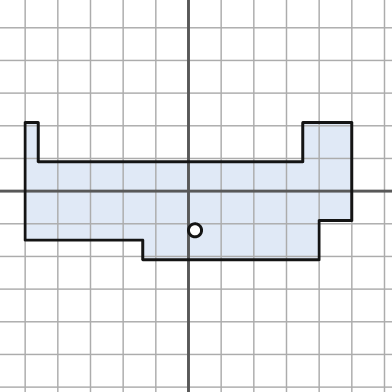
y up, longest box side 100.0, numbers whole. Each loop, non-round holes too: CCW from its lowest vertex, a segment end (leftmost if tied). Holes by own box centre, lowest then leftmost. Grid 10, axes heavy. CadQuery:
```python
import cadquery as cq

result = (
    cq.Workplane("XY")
    .moveTo(-14.0, -21.0)
    .lineTo(40.0, -21.0)
    .lineTo(40.0, -9.0)
    .lineTo(50.0, -9.0)
    .lineTo(50.0, 21.0)
    .lineTo(35.0, 21.0)
    .lineTo(35.0, 9.0)
    .lineTo(-46.0, 9.0)
    .lineTo(-46.0, 21.0)
    .lineTo(-50.0, 21.0)
    .lineTo(-50.0, -15.0)
    .lineTo(-14.0, -15.0)
    .close()
    .moveTo(2.0, -12.0)
    .circle(2.0)
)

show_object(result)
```